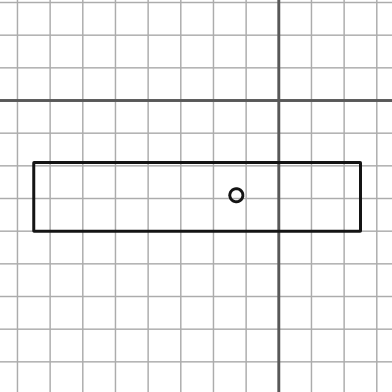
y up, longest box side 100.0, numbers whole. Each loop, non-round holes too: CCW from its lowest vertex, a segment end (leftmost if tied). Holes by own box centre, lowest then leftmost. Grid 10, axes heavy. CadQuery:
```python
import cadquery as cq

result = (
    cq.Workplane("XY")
    .moveTo(-75.0, -40.0)
    .lineTo(25.0, -40.0)
    .lineTo(25.0, -19.0)
    .lineTo(-75.0, -19.0)
    .close()
    .moveTo(-13.0, -29.0)
    .circle(2.0)
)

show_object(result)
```